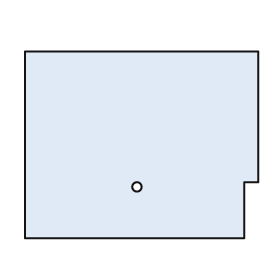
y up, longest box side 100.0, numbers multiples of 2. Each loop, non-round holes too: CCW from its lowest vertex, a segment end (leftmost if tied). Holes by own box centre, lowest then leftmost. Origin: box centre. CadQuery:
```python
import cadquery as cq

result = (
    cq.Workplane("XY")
    .moveTo(-50.0, -40.0)
    .lineTo(44.0, -40.0)
    .lineTo(44.0, -16.0)
    .lineTo(50.0, -16.0)
    .lineTo(50.0, 40.0)
    .lineTo(-50.0, 40.0)
    .close()
    .moveTo(-2.0, -18.0)
    .circle(2.0)
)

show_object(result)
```